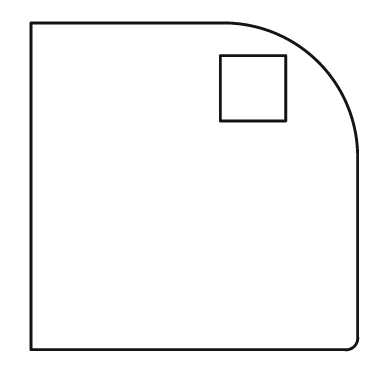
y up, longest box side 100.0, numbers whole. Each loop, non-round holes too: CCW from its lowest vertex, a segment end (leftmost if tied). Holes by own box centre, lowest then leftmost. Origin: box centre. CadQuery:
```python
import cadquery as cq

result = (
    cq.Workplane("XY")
    .moveTo(-50.0, -50.0)
    .lineTo(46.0, -50.0)
    .threePointArc((49.0, -49.0), (50.0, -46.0))
    .lineTo(50.0, 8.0)
    .threePointArc((38.0, 38.0), (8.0, 50.0))
    .lineTo(-50.0, 50.0)
    .close()
    .moveTo(8.0, 20.0)
    .lineTo(28.0, 20.0)
    .lineTo(28.0, 40.0)
    .lineTo(8.0, 40.0)
    .close()
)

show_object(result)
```